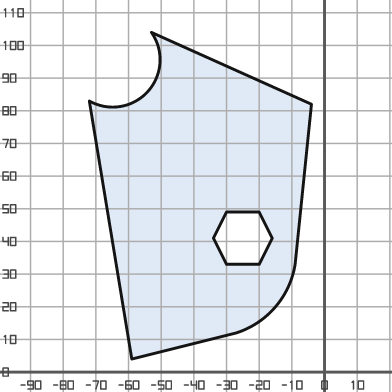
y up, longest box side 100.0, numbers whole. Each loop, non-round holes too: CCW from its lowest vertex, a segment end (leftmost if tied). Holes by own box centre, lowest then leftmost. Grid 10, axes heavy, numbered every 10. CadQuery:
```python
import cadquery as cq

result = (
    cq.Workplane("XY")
    .moveTo(-59.0, 4.0)
    .lineTo(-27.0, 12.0)
    .threePointArc((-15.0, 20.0), (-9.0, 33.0))
    .lineTo(-4.0, 82.0)
    .lineTo(-53.0, 104.0)
    .threePointArc((-54.0, 86.0), (-72.0, 83.0))
    .close()
    .moveTo(-30.0, 33.0)
    .lineTo(-20.0, 33.0)
    .lineTo(-16.0, 41.0)
    .lineTo(-20.0, 49.0)
    .lineTo(-30.0, 49.0)
    .lineTo(-34.0, 41.0)
    .close()
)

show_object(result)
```